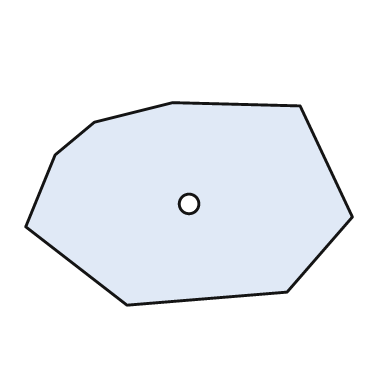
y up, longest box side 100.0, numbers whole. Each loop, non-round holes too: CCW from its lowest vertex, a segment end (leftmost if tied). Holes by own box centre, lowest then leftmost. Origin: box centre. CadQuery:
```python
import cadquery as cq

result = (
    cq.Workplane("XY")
    .moveTo(-19.0, -31.0)
    .lineTo(30.0, -27.0)
    .lineTo(50.0, -4.0)
    .lineTo(34.0, 30.0)
    .lineTo(-5.0, 31.0)
    .lineTo(-29.0, 25.0)
    .lineTo(-41.0, 15.0)
    .lineTo(-50.0, -7.0)
    .close()
    .moveTo(0.0, 0.0)
    .circle(3.0)
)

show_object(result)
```